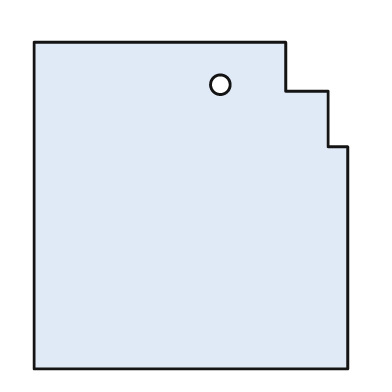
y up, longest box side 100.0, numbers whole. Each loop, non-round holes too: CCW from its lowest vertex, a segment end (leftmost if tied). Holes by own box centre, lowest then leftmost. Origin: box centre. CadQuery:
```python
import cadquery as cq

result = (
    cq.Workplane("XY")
    .moveTo(-48.0, -50.0)
    .lineTo(48.0, -50.0)
    .lineTo(48.0, 18.0)
    .lineTo(42.0, 18.0)
    .lineTo(42.0, 35.0)
    .lineTo(29.0, 35.0)
    .lineTo(29.0, 50.0)
    .lineTo(-48.0, 50.0)
    .close()
    .moveTo(9.0, 37.0)
    .circle(3.0)
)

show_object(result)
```